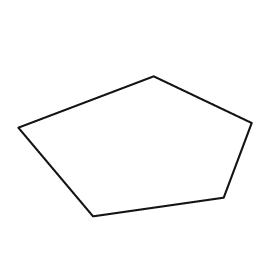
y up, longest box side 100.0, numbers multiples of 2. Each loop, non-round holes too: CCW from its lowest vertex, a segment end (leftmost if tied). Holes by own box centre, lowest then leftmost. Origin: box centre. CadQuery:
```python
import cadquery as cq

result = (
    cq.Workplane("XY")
    .moveTo(-18.0, -30.0)
    .lineTo(38.0, -22.0)
    .lineTo(50.0, 10.0)
    .lineTo(8.0, 30.0)
    .lineTo(-50.0, 8.0)
    .close()
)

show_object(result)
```